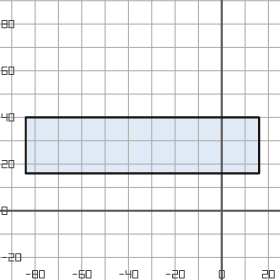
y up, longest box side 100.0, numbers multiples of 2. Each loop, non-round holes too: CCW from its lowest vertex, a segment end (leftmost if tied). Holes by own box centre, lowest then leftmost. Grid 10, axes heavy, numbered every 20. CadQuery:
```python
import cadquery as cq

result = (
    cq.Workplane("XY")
    .moveTo(-84.0, 16.0)
    .lineTo(16.0, 16.0)
    .lineTo(16.0, 40.0)
    .lineTo(-84.0, 40.0)
    .close()
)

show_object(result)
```